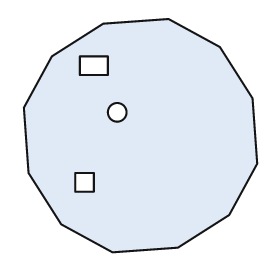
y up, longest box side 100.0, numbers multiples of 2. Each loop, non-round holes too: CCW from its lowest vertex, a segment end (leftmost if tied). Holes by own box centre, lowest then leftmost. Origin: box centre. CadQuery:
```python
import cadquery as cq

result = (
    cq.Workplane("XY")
    .moveTo(-12.0, -50.0)
    .lineTo(16.0, -48.0)
    .lineTo(38.0, -34.0)
    .lineTo(50.0, -12.0)
    .lineTo(48.0, 16.0)
    .lineTo(34.0, 38.0)
    .lineTo(12.0, 50.0)
    .lineTo(-16.0, 48.0)
    .lineTo(-38.0, 34.0)
    .lineTo(-50.0, 12.0)
    .lineTo(-48.0, -16.0)
    .lineTo(-34.0, -38.0)
    .close()
    .moveTo(-28.0, -24.0)
    .lineTo(-20.0, -24.0)
    .lineTo(-20.0, -16.0)
    .lineTo(-28.0, -16.0)
    .close()
    .moveTo(-10.0, 10.0)
    .circle(4.0)
    .moveTo(-26.0, 26.0)
    .lineTo(-14.0, 26.0)
    .lineTo(-14.0, 34.0)
    .lineTo(-26.0, 34.0)
    .close()
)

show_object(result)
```